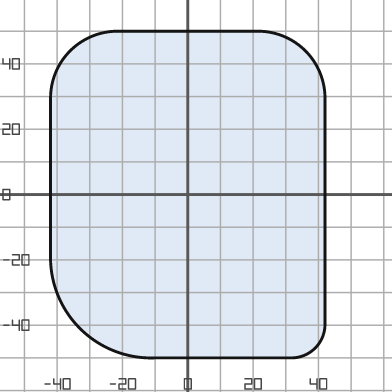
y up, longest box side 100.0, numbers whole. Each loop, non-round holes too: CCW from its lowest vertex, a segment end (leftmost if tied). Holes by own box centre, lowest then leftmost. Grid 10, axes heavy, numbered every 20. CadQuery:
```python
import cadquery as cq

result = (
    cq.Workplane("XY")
    .moveTo(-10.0, -50.0)
    .lineTo(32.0, -50.0)
    .threePointArc((39.0, -47.0), (42.0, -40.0))
    .lineTo(42.0, 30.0)
    .threePointArc((36.0, 44.0), (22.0, 50.0))
    .lineTo(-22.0, 50.0)
    .threePointArc((-36.0, 44.0), (-42.0, 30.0))
    .lineTo(-42.0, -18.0)
    .threePointArc((-33.0, -41.0), (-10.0, -50.0))
    .close()
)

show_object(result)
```